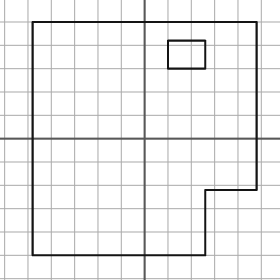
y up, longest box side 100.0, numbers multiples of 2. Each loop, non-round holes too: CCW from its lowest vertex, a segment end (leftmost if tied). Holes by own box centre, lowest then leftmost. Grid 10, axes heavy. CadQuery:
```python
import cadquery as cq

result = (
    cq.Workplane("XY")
    .moveTo(-48.0, -50.0)
    .lineTo(26.0, -50.0)
    .lineTo(26.0, -22.0)
    .lineTo(48.0, -22.0)
    .lineTo(48.0, 50.0)
    .lineTo(-48.0, 50.0)
    .close()
    .moveTo(10.0, 30.0)
    .lineTo(26.0, 30.0)
    .lineTo(26.0, 42.0)
    .lineTo(10.0, 42.0)
    .close()
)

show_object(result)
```